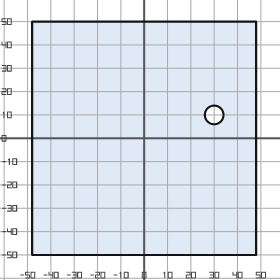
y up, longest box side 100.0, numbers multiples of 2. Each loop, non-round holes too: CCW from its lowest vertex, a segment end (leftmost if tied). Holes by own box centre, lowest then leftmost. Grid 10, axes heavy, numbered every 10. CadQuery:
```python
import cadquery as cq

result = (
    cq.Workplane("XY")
    .moveTo(-48.0, -50.0)
    .lineTo(48.0, -50.0)
    .lineTo(48.0, 50.0)
    .lineTo(-48.0, 50.0)
    .close()
    .moveTo(30.0, 10.0)
    .circle(4.0)
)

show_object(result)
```